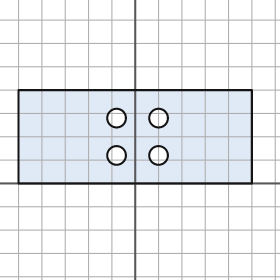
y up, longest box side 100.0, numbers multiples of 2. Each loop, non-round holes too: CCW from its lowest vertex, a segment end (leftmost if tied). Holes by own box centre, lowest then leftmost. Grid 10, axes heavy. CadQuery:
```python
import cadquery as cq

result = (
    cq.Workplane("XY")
    .moveTo(-50.0, 0.0)
    .lineTo(50.0, 0.0)
    .lineTo(50.0, 40.0)
    .lineTo(-50.0, 40.0)
    .close()
    .moveTo(-8.0, 12.0)
    .circle(4.0)
    .moveTo(10.0, 12.0)
    .circle(4.0)
    .moveTo(-8.0, 28.0)
    .circle(4.0)
    .moveTo(10.0, 28.0)
    .circle(4.0)
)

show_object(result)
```